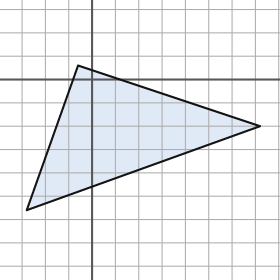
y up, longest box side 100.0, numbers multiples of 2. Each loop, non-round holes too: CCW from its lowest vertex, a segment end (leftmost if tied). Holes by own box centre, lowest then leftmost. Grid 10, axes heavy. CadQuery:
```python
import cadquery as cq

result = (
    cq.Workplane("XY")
    .moveTo(-28.0, -56.0)
    .lineTo(72.0, -20.0)
    .lineTo(-6.0, 6.0)
    .close()
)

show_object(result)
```